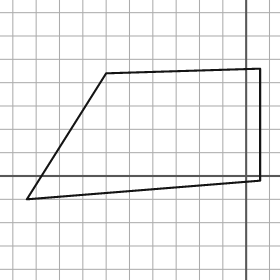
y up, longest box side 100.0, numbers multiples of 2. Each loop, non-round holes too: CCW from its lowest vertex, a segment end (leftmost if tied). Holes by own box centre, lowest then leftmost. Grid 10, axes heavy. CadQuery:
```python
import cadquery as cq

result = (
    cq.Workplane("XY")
    .moveTo(-94.0, -10.0)
    .lineTo(6.0, -2.0)
    .lineTo(6.0, 46.0)
    .lineTo(-60.0, 44.0)
    .close()
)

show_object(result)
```